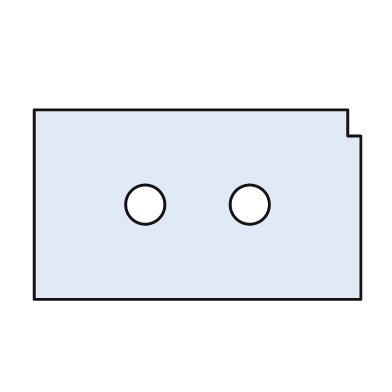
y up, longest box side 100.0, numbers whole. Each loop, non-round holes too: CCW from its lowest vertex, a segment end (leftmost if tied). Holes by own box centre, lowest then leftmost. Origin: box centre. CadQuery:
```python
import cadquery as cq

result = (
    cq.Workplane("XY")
    .moveTo(-50.0, -29.0)
    .lineTo(50.0, -29.0)
    .lineTo(50.0, 21.0)
    .lineTo(46.0, 21.0)
    .lineTo(46.0, 29.0)
    .lineTo(-50.0, 29.0)
    .close()
    .moveTo(-16.0, 0.0)
    .circle(6.0)
    .moveTo(16.0, 0.0)
    .circle(6.0)
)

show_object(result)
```